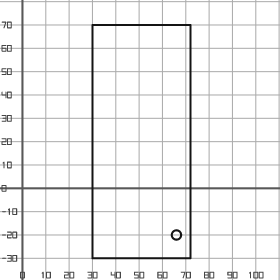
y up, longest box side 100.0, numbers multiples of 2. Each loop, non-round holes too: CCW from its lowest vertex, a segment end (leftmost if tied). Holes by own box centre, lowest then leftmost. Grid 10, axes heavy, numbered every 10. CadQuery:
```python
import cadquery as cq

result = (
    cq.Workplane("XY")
    .moveTo(30.0, -30.0)
    .lineTo(72.0, -30.0)
    .lineTo(72.0, 70.0)
    .lineTo(30.0, 70.0)
    .close()
    .moveTo(66.0, -20.0)
    .circle(2.0)
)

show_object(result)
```